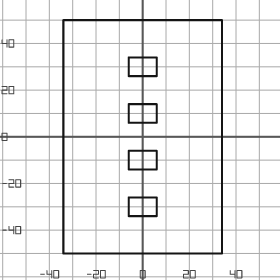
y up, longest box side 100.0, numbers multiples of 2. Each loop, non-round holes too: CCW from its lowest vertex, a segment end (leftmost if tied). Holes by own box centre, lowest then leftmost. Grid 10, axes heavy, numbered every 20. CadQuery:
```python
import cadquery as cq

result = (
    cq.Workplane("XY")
    .moveTo(-34.0, -50.0)
    .lineTo(34.0, -50.0)
    .lineTo(34.0, 50.0)
    .lineTo(-34.0, 50.0)
    .close()
    .moveTo(-6.0, -34.0)
    .lineTo(6.0, -34.0)
    .lineTo(6.0, -26.0)
    .lineTo(-6.0, -26.0)
    .close()
    .moveTo(-6.0, -14.0)
    .lineTo(6.0, -14.0)
    .lineTo(6.0, -6.0)
    .lineTo(-6.0, -6.0)
    .close()
    .moveTo(-6.0, 6.0)
    .lineTo(6.0, 6.0)
    .lineTo(6.0, 14.0)
    .lineTo(-6.0, 14.0)
    .close()
    .moveTo(-6.0, 26.0)
    .lineTo(6.0, 26.0)
    .lineTo(6.0, 34.0)
    .lineTo(-6.0, 34.0)
    .close()
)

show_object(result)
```